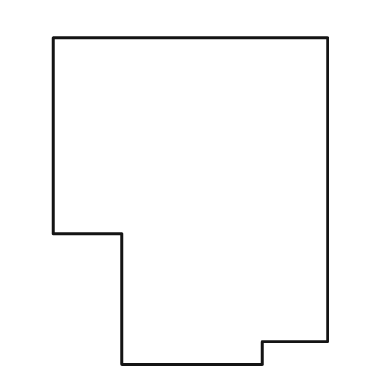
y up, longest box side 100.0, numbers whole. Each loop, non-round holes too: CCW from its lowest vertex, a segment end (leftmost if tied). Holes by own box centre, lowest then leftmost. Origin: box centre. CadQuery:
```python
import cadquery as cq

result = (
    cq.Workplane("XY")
    .moveTo(-21.0, -50.0)
    .lineTo(22.0, -50.0)
    .lineTo(22.0, -43.0)
    .lineTo(42.0, -43.0)
    .lineTo(42.0, 50.0)
    .lineTo(-42.0, 50.0)
    .lineTo(-42.0, -10.0)
    .lineTo(-21.0, -10.0)
    .close()
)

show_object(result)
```